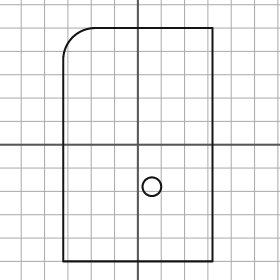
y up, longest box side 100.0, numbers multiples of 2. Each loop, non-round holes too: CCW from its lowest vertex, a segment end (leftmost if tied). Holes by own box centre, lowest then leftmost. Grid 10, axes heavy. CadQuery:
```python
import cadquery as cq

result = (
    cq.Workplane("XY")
    .moveTo(-32.0, -50.0)
    .lineTo(32.0, -50.0)
    .lineTo(32.0, 50.0)
    .lineTo(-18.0, 50.0)
    .threePointArc((-28.0, 46.0), (-32.0, 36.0))
    .close()
    .moveTo(6.0, -18.0)
    .circle(4.0)
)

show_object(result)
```